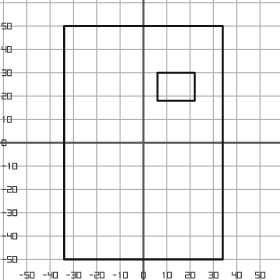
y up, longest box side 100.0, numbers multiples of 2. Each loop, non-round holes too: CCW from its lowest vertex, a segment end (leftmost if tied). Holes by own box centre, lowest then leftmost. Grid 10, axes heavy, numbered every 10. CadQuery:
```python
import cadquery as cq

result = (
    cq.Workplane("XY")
    .moveTo(-34.0, -50.0)
    .lineTo(34.0, -50.0)
    .lineTo(34.0, 50.0)
    .lineTo(-34.0, 50.0)
    .close()
    .moveTo(6.0, 18.0)
    .lineTo(22.0, 18.0)
    .lineTo(22.0, 30.0)
    .lineTo(6.0, 30.0)
    .close()
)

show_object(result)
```